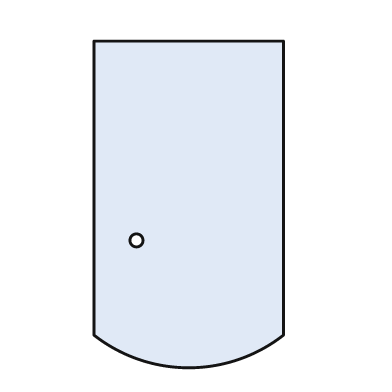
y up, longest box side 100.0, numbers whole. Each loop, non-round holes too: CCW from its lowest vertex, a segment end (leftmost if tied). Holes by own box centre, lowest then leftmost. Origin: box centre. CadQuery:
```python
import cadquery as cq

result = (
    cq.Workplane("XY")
    .moveTo(-29.0, -40.0)
    .threePointArc((0.0, -50.0), (29.0, -40.0))
    .lineTo(29.0, 50.0)
    .lineTo(-29.0, 50.0)
    .close()
    .moveTo(-16.0, -11.0)
    .circle(2.0)
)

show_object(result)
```